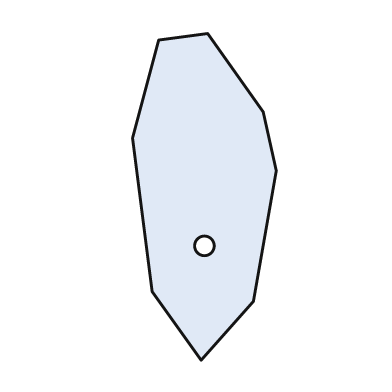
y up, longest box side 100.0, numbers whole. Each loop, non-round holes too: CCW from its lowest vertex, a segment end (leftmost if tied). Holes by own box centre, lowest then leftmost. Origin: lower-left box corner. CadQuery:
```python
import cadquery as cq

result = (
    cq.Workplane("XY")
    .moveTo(21.0, 0.0)
    .lineTo(37.0, 18.0)
    .lineTo(44.0, 58.0)
    .lineTo(40.0, 76.0)
    .lineTo(23.0, 100.0)
    .lineTo(8.0, 98.0)
    .lineTo(0.0, 68.0)
    .lineTo(6.0, 21.0)
    .close()
    .moveTo(22.0, 35.0)
    .circle(3.0)
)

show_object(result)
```